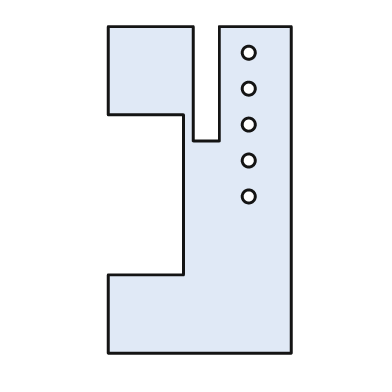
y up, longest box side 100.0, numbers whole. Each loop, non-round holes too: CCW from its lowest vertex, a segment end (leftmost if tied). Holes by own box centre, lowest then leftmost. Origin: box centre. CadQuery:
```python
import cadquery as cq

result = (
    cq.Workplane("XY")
    .moveTo(-28.0, -50.0)
    .lineTo(28.0, -50.0)
    .lineTo(28.0, 50.0)
    .lineTo(6.0, 50.0)
    .lineTo(6.0, 15.0)
    .lineTo(-2.0, 15.0)
    .lineTo(-2.0, 50.0)
    .lineTo(-28.0, 50.0)
    .lineTo(-28.0, 23.0)
    .lineTo(-5.0, 23.0)
    .lineTo(-5.0, -26.0)
    .lineTo(-28.0, -26.0)
    .close()
    .moveTo(15.0, -2.0)
    .circle(2.0)
    .moveTo(15.0, 9.0)
    .circle(2.0)
    .moveTo(15.0, 20.0)
    .circle(2.0)
    .moveTo(15.0, 31.0)
    .circle(2.0)
    .moveTo(15.0, 42.0)
    .circle(2.0)
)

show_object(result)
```